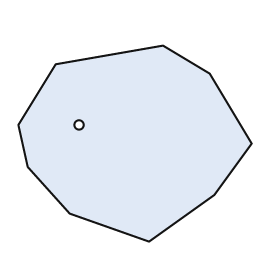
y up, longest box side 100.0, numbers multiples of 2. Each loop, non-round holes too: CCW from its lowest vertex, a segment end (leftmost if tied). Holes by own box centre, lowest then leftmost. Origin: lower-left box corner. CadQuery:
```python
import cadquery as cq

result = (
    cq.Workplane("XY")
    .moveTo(56.0, 0.0)
    .lineTo(84.0, 20.0)
    .lineTo(100.0, 42.0)
    .lineTo(82.0, 72.0)
    .lineTo(62.0, 84.0)
    .lineTo(16.0, 76.0)
    .lineTo(0.0, 50.0)
    .lineTo(4.0, 32.0)
    .lineTo(22.0, 12.0)
    .close()
    .moveTo(26.0, 50.0)
    .circle(2.0)
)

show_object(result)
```